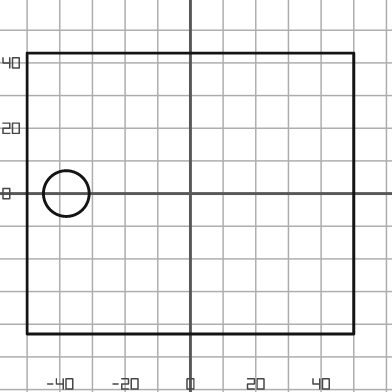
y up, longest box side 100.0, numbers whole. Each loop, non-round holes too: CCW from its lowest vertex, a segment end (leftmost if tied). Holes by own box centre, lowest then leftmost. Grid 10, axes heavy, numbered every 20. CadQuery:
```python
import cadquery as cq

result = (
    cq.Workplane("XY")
    .moveTo(-50.0, -43.0)
    .lineTo(50.0, -43.0)
    .lineTo(50.0, 43.0)
    .lineTo(-50.0, 43.0)
    .close()
    .moveTo(-38.0, 0.0)
    .circle(7.0)
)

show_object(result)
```